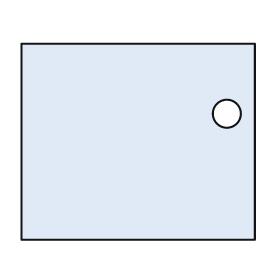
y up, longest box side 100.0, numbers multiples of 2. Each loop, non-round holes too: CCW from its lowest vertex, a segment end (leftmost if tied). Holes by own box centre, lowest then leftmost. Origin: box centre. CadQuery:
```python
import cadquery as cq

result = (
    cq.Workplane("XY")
    .moveTo(-50.0, -42.0)
    .lineTo(50.0, -42.0)
    .lineTo(50.0, 42.0)
    .lineTo(-50.0, 42.0)
    .close()
    .moveTo(38.0, 12.0)
    .circle(6.0)
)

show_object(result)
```